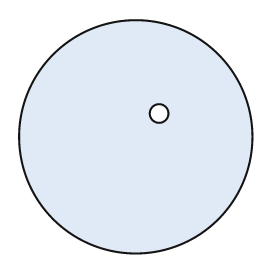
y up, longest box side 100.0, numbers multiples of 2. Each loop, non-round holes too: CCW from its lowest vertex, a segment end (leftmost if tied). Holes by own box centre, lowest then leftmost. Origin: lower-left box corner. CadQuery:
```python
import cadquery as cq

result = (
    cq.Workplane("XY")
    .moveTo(50.0, 50.0)
    .circle(50.0)
    .moveTo(60.0, 60.0)
    .circle(4.0)
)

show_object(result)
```